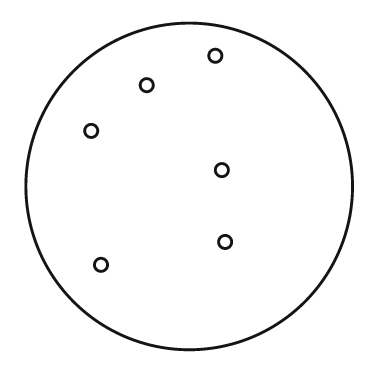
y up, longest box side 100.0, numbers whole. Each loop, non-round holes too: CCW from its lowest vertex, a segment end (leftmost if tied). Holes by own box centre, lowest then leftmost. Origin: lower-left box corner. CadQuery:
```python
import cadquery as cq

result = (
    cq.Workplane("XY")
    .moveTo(50.0, 50.0)
    .circle(50.0)
    .moveTo(23.0, 26.0)
    .circle(2.0)
    .moveTo(61.0, 33.0)
    .circle(2.0)
    .moveTo(60.0, 55.0)
    .circle(2.0)
    .moveTo(20.0, 67.0)
    .circle(2.0)
    .moveTo(37.0, 81.0)
    .circle(2.0)
    .moveTo(58.0, 90.0)
    .circle(2.0)
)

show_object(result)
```